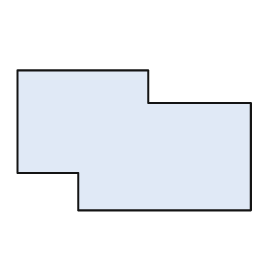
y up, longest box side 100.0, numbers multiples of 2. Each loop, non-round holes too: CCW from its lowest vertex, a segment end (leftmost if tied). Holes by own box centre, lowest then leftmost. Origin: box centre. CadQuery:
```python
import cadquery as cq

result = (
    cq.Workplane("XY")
    .moveTo(-24.0, -30.0)
    .lineTo(50.0, -30.0)
    .lineTo(50.0, 16.0)
    .lineTo(6.0, 16.0)
    .lineTo(6.0, 30.0)
    .lineTo(-50.0, 30.0)
    .lineTo(-50.0, -14.0)
    .lineTo(-24.0, -14.0)
    .close()
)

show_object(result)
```